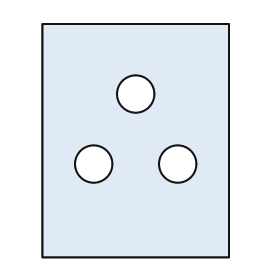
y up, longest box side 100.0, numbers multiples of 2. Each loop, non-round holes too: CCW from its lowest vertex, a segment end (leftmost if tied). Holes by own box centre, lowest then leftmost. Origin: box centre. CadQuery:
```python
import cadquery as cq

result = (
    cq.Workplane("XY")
    .moveTo(-40.0, -50.0)
    .lineTo(40.0, -50.0)
    .lineTo(40.0, 50.0)
    .lineTo(-40.0, 50.0)
    .close()
    .moveTo(-18.0, -10.0)
    .circle(8.0)
    .moveTo(18.0, -10.0)
    .circle(8.0)
    .moveTo(0.0, 20.0)
    .circle(8.0)
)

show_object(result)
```